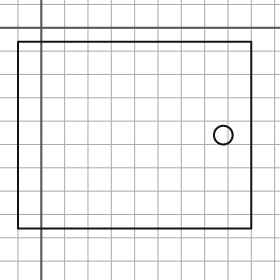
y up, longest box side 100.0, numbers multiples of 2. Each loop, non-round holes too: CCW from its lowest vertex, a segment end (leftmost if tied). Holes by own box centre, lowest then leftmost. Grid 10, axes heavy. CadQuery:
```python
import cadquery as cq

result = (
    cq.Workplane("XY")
    .moveTo(-10.0, -86.0)
    .lineTo(90.0, -86.0)
    .lineTo(90.0, -6.0)
    .lineTo(-10.0, -6.0)
    .close()
    .moveTo(78.0, -46.0)
    .circle(4.0)
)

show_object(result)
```